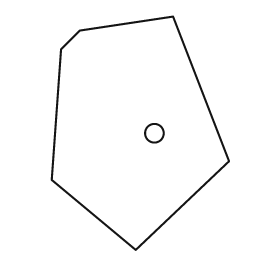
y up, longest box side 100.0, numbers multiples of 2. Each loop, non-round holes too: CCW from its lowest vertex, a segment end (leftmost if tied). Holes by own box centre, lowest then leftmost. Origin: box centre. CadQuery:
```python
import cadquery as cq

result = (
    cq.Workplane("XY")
    .moveTo(-2.0, -50.0)
    .lineTo(38.0, -12.0)
    .lineTo(14.0, 50.0)
    .lineTo(-26.0, 44.0)
    .lineTo(-34.0, 36.0)
    .lineTo(-38.0, -20.0)
    .close()
    .moveTo(6.0, 0.0)
    .circle(4.0)
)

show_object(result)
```